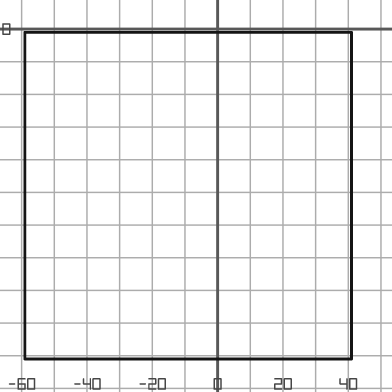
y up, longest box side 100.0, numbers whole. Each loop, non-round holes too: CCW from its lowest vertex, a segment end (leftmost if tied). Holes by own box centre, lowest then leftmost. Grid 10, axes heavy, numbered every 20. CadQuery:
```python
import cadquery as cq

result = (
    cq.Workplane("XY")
    .moveTo(-59.0, -101.0)
    .lineTo(41.0, -101.0)
    .lineTo(41.0, -1.0)
    .lineTo(-59.0, -1.0)
    .close()
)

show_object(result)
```